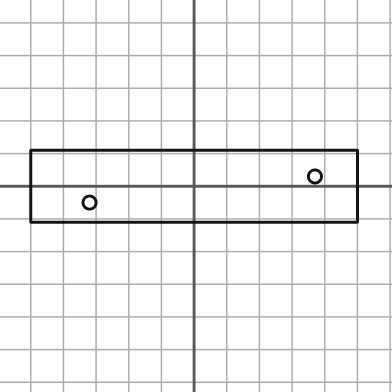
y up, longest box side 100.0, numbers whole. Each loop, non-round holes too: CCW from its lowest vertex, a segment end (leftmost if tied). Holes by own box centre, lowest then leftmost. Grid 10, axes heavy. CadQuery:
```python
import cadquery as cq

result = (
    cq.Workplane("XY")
    .moveTo(-50.0, -11.0)
    .lineTo(50.0, -11.0)
    .lineTo(50.0, 11.0)
    .lineTo(-50.0, 11.0)
    .close()
    .moveTo(-32.0, -5.0)
    .circle(2.0)
    .moveTo(37.0, 3.0)
    .circle(2.0)
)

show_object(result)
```